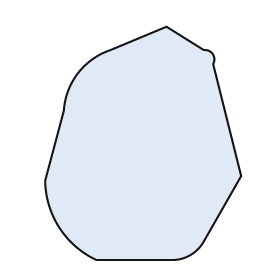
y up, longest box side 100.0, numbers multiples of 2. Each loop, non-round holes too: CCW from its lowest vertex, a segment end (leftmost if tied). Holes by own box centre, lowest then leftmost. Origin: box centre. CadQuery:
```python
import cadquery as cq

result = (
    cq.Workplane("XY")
    .moveTo(-20.0, -50.0)
    .lineTo(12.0, -50.0)
    .threePointArc((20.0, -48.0), (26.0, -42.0))
    .lineTo(42.0, -14.0)
    .lineTo(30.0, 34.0)
    .threePointArc((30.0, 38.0), (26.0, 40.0))
    .lineTo(10.0, 50.0)
    .lineTo(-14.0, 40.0)
    .threePointArc((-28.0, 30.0), (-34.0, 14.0))
    .lineTo(-42.0, -16.0)
    .threePointArc((-36.0, -36.0), (-20.0, -50.0))
    .close()
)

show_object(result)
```